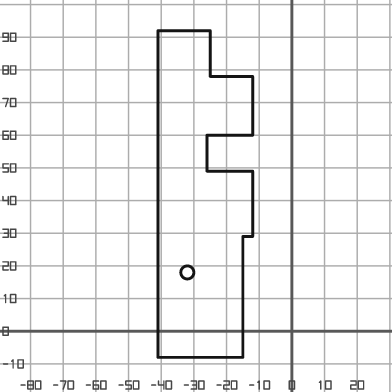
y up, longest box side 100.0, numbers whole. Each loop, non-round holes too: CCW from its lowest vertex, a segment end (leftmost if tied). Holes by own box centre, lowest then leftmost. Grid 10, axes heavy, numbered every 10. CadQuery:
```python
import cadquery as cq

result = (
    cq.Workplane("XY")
    .moveTo(-41.0, -8.0)
    .lineTo(-15.0, -8.0)
    .lineTo(-15.0, 29.0)
    .lineTo(-12.0, 29.0)
    .lineTo(-12.0, 49.0)
    .lineTo(-26.0, 49.0)
    .lineTo(-26.0, 60.0)
    .lineTo(-12.0, 60.0)
    .lineTo(-12.0, 78.0)
    .lineTo(-25.0, 78.0)
    .lineTo(-25.0, 92.0)
    .lineTo(-41.0, 92.0)
    .close()
    .moveTo(-32.0, 18.0)
    .circle(2.0)
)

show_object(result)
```